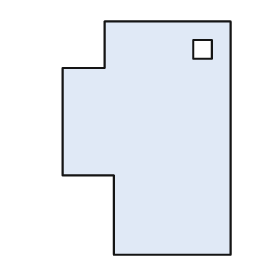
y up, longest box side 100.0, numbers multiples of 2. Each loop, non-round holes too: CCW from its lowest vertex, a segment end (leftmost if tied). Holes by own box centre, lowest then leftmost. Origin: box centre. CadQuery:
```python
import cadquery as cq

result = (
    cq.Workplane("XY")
    .moveTo(-14.0, -50.0)
    .lineTo(36.0, -50.0)
    .lineTo(36.0, 50.0)
    .lineTo(-18.0, 50.0)
    .lineTo(-18.0, 30.0)
    .lineTo(-36.0, 30.0)
    .lineTo(-36.0, -16.0)
    .lineTo(-14.0, -16.0)
    .close()
    .moveTo(20.0, 34.0)
    .lineTo(28.0, 34.0)
    .lineTo(28.0, 42.0)
    .lineTo(20.0, 42.0)
    .close()
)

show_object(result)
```